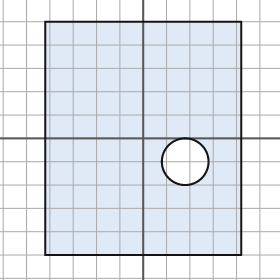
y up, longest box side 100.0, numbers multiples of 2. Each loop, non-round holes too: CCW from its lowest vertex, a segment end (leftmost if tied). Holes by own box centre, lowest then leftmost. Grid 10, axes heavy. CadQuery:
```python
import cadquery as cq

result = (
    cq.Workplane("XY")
    .moveTo(-42.0, -50.0)
    .lineTo(42.0, -50.0)
    .lineTo(42.0, 50.0)
    .lineTo(-42.0, 50.0)
    .close()
    .moveTo(18.0, -10.0)
    .circle(10.0)
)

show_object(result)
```